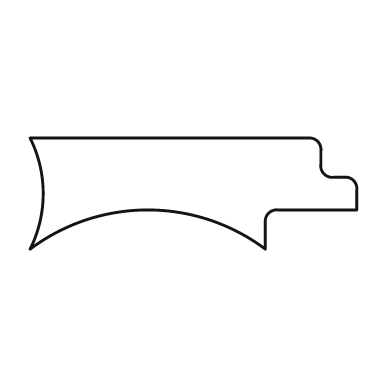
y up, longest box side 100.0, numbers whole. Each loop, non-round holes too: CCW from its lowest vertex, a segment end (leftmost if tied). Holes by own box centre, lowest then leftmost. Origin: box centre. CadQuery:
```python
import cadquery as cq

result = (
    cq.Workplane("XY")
    .moveTo(-50.0, -17.0)
    .threePointArc((-14.0, -5.0), (22.0, -17.0))
    .lineTo(22.0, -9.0)
    .threePointArc((23.0, -6.0), (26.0, -5.0))
    .lineTo(50.0, -5.0)
    .lineTo(50.0, 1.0)
    .threePointArc((49.0, 4.0), (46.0, 5.0))
    .lineTo(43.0, 5.0)
    .threePointArc((40.0, 6.0), (39.0, 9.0))
    .lineTo(39.0, 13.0)
    .threePointArc((38.0, 16.0), (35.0, 17.0))
    .lineTo(-50.0, 17.0)
    .threePointArc((-46.0, 0.0), (-50.0, -17.0))
    .close()
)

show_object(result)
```